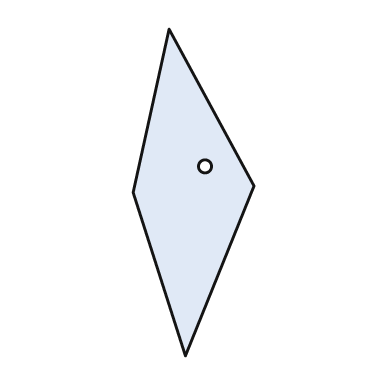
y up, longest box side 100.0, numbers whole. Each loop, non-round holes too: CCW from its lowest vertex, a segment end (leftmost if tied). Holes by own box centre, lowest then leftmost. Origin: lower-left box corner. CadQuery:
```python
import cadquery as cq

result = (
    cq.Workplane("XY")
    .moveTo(16.0, 0.0)
    .lineTo(37.0, 52.0)
    .lineTo(11.0, 100.0)
    .lineTo(0.0, 50.0)
    .close()
    .moveTo(22.0, 58.0)
    .circle(2.0)
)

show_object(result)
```